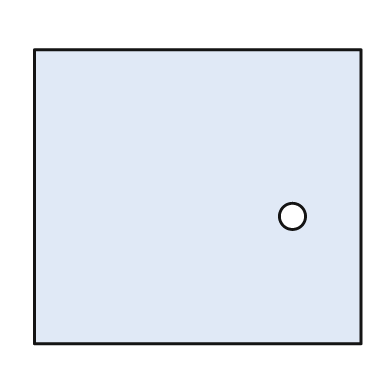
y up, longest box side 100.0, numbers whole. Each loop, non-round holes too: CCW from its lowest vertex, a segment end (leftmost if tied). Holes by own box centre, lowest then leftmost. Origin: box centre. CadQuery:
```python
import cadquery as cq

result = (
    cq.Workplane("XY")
    .moveTo(-50.0, -45.0)
    .lineTo(50.0, -45.0)
    .lineTo(50.0, 45.0)
    .lineTo(-50.0, 45.0)
    .close()
    .moveTo(29.0, -6.0)
    .circle(4.0)
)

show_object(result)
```